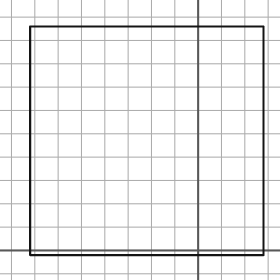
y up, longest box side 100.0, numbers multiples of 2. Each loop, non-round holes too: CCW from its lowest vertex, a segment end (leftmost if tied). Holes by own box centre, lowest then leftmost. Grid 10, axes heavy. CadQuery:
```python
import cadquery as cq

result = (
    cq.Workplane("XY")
    .moveTo(-72.0, -2.0)
    .lineTo(28.0, -2.0)
    .lineTo(28.0, 96.0)
    .lineTo(-72.0, 96.0)
    .close()
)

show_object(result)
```